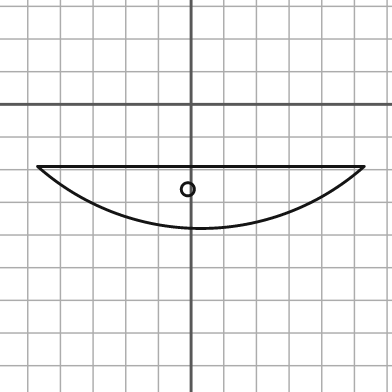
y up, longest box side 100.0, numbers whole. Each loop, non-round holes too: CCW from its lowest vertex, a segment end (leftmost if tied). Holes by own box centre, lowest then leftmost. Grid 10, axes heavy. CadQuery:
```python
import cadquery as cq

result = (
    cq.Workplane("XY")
    .moveTo(-47.0, -19.0)
    .threePointArc((3.0, -38.0), (53.0, -19.0))
    .close()
    .moveTo(-1.0, -26.0)
    .circle(2.0)
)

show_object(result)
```